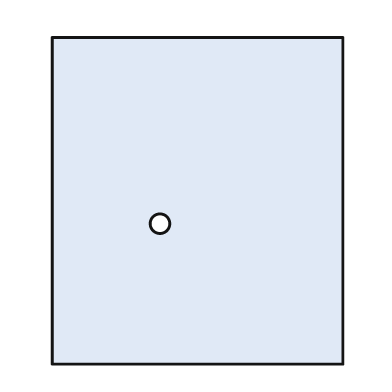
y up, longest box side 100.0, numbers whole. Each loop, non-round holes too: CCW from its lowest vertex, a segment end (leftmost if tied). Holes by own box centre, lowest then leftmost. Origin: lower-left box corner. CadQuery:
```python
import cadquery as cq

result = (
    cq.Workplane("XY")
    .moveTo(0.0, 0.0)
    .lineTo(89.0, 0.0)
    .lineTo(89.0, 100.0)
    .lineTo(0.0, 100.0)
    .close()
    .moveTo(33.0, 43.0)
    .circle(3.0)
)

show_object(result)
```